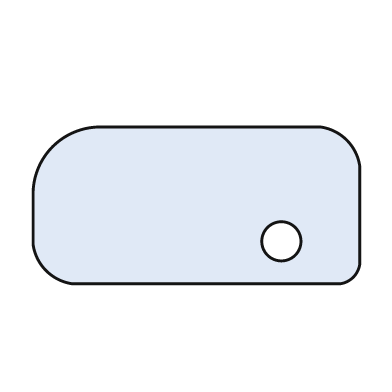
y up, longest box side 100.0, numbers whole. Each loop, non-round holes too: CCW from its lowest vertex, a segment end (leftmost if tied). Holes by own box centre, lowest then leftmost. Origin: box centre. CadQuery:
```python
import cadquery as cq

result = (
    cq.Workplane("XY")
    .moveTo(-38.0, -24.0)
    .lineTo(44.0, -24.0)
    .threePointArc((48.0, -22.0), (50.0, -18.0))
    .lineTo(50.0, 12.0)
    .threePointArc((46.0, 20.0), (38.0, 24.0))
    .lineTo(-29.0, 24.0)
    .threePointArc((-44.0, 18.0), (-50.0, 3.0))
    .lineTo(-50.0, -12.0)
    .threePointArc((-46.0, -20.0), (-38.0, -24.0))
    .close()
    .moveTo(26.0, -11.0)
    .circle(6.0)
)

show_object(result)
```